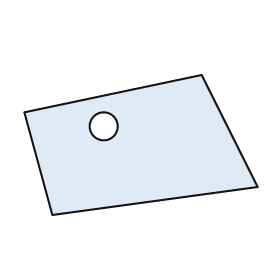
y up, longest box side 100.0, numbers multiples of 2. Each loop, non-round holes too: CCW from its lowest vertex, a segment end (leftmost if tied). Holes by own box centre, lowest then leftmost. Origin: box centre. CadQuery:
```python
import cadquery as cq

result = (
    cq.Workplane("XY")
    .moveTo(-38.0, -30.0)
    .lineTo(50.0, -18.0)
    .lineTo(26.0, 30.0)
    .lineTo(-50.0, 14.0)
    .close()
    .moveTo(-16.0, 8.0)
    .circle(6.0)
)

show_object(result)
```